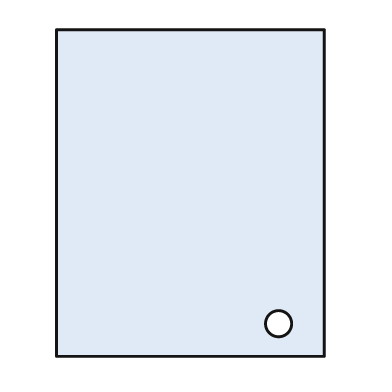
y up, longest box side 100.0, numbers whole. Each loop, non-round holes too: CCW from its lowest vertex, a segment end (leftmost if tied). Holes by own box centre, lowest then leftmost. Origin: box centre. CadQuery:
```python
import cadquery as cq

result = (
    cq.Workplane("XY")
    .moveTo(-41.0, -50.0)
    .lineTo(41.0, -50.0)
    .lineTo(41.0, 50.0)
    .lineTo(-41.0, 50.0)
    .close()
    .moveTo(27.0, -40.0)
    .circle(4.0)
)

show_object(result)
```